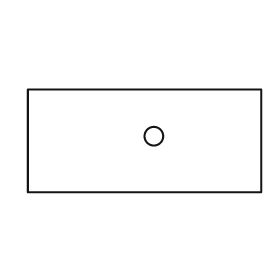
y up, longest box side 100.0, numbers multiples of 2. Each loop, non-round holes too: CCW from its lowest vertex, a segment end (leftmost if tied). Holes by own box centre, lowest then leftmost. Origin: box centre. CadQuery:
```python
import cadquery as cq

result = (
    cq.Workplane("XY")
    .moveTo(-50.0, -22.0)
    .lineTo(50.0, -22.0)
    .lineTo(50.0, 22.0)
    .lineTo(-50.0, 22.0)
    .close()
    .moveTo(4.0, 2.0)
    .circle(4.0)
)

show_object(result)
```